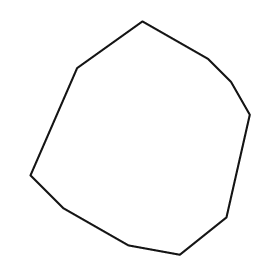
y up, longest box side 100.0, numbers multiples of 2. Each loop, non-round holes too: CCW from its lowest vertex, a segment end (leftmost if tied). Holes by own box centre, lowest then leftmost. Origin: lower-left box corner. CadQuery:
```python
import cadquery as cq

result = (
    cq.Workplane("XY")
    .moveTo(64.0, 0.0)
    .lineTo(84.0, 16.0)
    .lineTo(94.0, 60.0)
    .lineTo(86.0, 74.0)
    .lineTo(76.0, 84.0)
    .lineTo(48.0, 100.0)
    .lineTo(20.0, 80.0)
    .lineTo(0.0, 34.0)
    .lineTo(14.0, 20.0)
    .lineTo(42.0, 4.0)
    .close()
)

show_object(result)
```